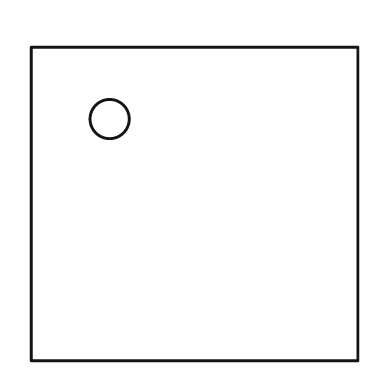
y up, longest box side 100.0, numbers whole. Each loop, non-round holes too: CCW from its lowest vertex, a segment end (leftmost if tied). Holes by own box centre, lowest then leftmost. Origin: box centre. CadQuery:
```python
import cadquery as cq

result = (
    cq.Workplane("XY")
    .moveTo(-50.0, -48.0)
    .lineTo(50.0, -48.0)
    .lineTo(50.0, 48.0)
    .lineTo(-50.0, 48.0)
    .close()
    .moveTo(-26.0, 26.0)
    .circle(6.0)
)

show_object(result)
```